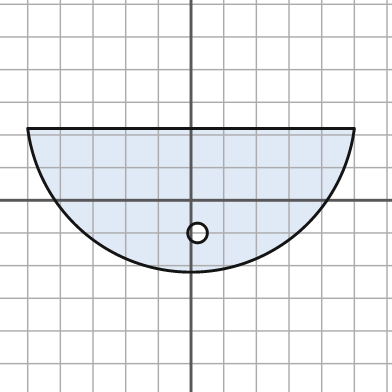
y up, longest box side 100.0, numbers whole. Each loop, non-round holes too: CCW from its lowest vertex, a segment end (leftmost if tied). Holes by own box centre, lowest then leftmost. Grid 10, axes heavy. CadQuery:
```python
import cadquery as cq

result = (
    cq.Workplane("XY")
    .moveTo(-50.0, 22.0)
    .threePointArc((0.0, -22.0), (50.0, 22.0))
    .close()
    .moveTo(2.0, -10.0)
    .circle(3.0)
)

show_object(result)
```